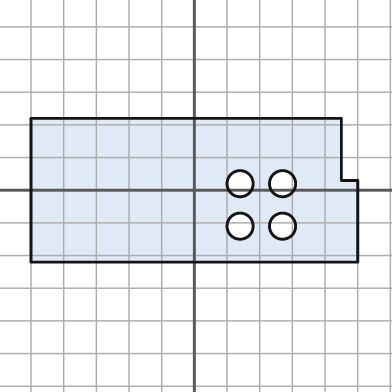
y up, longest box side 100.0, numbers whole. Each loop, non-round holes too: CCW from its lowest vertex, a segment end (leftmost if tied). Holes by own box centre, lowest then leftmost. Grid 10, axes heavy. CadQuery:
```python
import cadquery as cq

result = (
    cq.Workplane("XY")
    .moveTo(-50.0, -22.0)
    .lineTo(50.0, -22.0)
    .lineTo(50.0, 3.0)
    .lineTo(45.0, 3.0)
    .lineTo(45.0, 22.0)
    .lineTo(-50.0, 22.0)
    .close()
    .moveTo(14.0, -11.0)
    .circle(4.0)
    .moveTo(27.0, -11.0)
    .circle(4.0)
    .moveTo(14.0, 2.0)
    .circle(4.0)
    .moveTo(27.0, 2.0)
    .circle(4.0)
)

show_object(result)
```